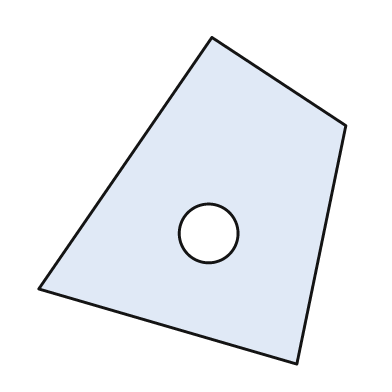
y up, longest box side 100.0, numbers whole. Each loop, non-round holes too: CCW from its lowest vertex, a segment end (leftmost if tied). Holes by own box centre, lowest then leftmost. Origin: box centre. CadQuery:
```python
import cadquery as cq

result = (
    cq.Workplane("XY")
    .moveTo(32.0, -50.0)
    .lineTo(47.0, 23.0)
    .lineTo(6.0, 50.0)
    .lineTo(-47.0, -27.0)
    .close()
    .moveTo(5.0, -10.0)
    .circle(9.0)
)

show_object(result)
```